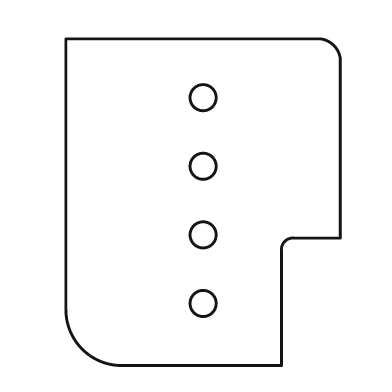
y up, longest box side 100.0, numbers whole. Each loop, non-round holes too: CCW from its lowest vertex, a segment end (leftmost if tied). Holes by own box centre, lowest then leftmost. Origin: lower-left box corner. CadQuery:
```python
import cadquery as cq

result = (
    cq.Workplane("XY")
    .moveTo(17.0, 0.0)
    .lineTo(66.0, 0.0)
    .lineTo(66.0, 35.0)
    .threePointArc((67.0, 38.0), (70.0, 39.0))
    .lineTo(84.0, 39.0)
    .lineTo(84.0, 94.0)
    .threePointArc((82.0, 98.0), (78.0, 100.0))
    .lineTo(0.0, 100.0)
    .lineTo(0.0, 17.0)
    .threePointArc((5.0, 5.0), (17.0, 0.0))
    .close()
    .moveTo(42.0, 19.0)
    .circle(4.0)
    .moveTo(42.0, 40.0)
    .circle(4.0)
    .moveTo(42.0, 61.0)
    .circle(4.0)
    .moveTo(42.0, 82.0)
    .circle(4.0)
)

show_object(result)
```